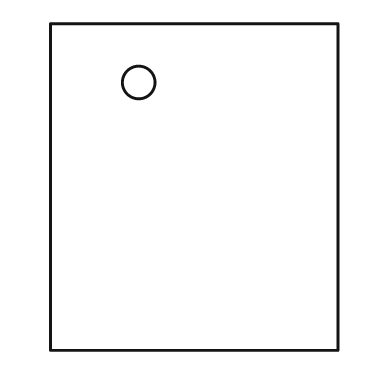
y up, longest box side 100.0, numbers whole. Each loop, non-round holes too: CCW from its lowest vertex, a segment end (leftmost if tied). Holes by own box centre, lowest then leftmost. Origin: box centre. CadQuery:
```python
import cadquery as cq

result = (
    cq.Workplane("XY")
    .moveTo(-44.0, -50.0)
    .lineTo(44.0, -50.0)
    .lineTo(44.0, 50.0)
    .lineTo(-44.0, 50.0)
    .close()
    .moveTo(-17.0, 32.0)
    .circle(5.0)
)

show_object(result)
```